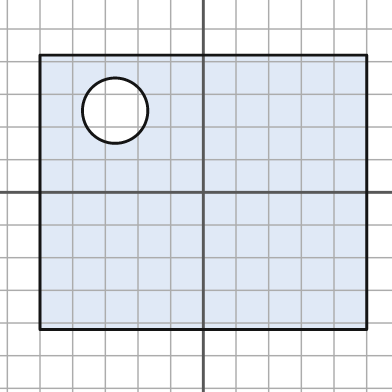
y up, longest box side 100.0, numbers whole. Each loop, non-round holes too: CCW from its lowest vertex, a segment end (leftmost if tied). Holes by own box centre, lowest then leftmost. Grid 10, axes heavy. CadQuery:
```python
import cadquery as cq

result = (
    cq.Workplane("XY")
    .moveTo(-50.0, -42.0)
    .lineTo(50.0, -42.0)
    .lineTo(50.0, 42.0)
    .lineTo(-50.0, 42.0)
    .close()
    .moveTo(-27.0, 25.0)
    .circle(10.0)
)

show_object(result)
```